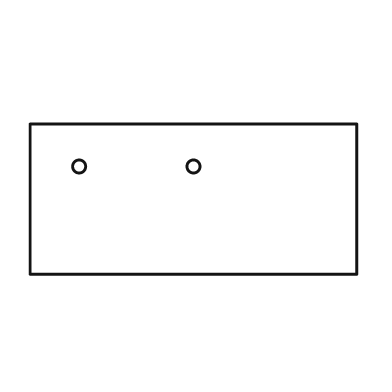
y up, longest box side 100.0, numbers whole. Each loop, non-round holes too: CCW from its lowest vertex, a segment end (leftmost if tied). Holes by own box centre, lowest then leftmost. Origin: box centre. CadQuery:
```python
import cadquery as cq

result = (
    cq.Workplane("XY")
    .moveTo(-50.0, -23.0)
    .lineTo(50.0, -23.0)
    .lineTo(50.0, 23.0)
    .lineTo(-50.0, 23.0)
    .close()
    .moveTo(-35.0, 10.0)
    .circle(2.0)
    .moveTo(0.0, 10.0)
    .circle(2.0)
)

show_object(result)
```